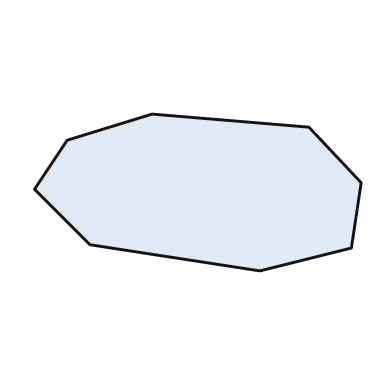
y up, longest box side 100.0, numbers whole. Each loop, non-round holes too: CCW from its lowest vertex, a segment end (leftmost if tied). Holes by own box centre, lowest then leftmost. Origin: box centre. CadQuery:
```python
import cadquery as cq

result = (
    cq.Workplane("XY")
    .moveTo(19.0, -24.0)
    .lineTo(47.0, -17.0)
    .lineTo(50.0, 3.0)
    .lineTo(34.0, 20.0)
    .lineTo(-14.0, 24.0)
    .lineTo(-40.0, 16.0)
    .lineTo(-50.0, 1.0)
    .lineTo(-33.0, -16.0)
    .close()
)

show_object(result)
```